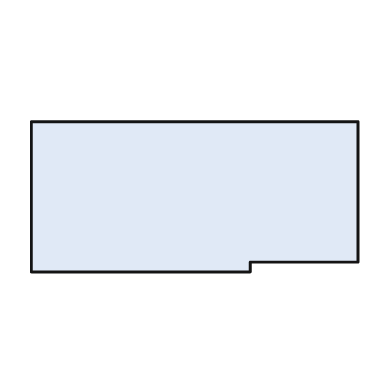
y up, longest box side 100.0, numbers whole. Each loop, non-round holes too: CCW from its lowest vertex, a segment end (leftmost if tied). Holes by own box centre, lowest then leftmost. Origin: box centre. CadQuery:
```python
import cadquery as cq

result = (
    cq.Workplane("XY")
    .moveTo(-50.0, -23.0)
    .lineTo(17.0, -23.0)
    .lineTo(17.0, -20.0)
    .lineTo(50.0, -20.0)
    .lineTo(50.0, 23.0)
    .lineTo(-50.0, 23.0)
    .close()
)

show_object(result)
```